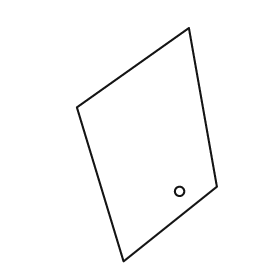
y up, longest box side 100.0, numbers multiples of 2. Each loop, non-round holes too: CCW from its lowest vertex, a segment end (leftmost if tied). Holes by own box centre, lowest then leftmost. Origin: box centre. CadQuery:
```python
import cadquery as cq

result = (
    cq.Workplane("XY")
    .moveTo(-10.0, -50.0)
    .lineTo(30.0, -18.0)
    .lineTo(18.0, 50.0)
    .lineTo(-30.0, 16.0)
    .close()
    .moveTo(14.0, -20.0)
    .circle(2.0)
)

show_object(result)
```